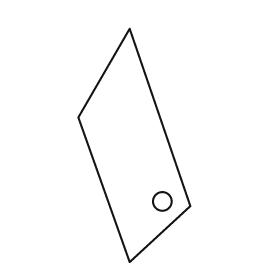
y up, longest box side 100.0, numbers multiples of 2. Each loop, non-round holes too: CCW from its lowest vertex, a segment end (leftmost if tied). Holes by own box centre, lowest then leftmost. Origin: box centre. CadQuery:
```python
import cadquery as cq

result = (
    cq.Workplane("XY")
    .moveTo(-2.0, -50.0)
    .lineTo(24.0, -26.0)
    .lineTo(-2.0, 50.0)
    .lineTo(-24.0, 12.0)
    .close()
    .moveTo(12.0, -24.0)
    .circle(4.0)
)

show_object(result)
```